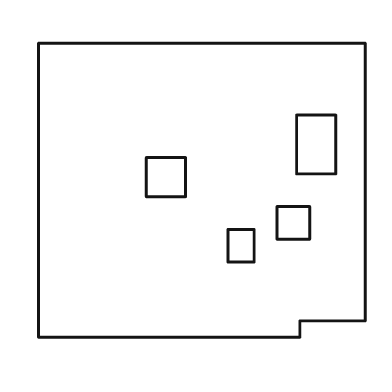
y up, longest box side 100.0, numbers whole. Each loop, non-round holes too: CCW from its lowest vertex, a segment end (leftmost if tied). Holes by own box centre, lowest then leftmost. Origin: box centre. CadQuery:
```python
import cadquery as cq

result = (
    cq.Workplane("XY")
    .moveTo(-50.0, -45.0)
    .lineTo(30.0, -45.0)
    .lineTo(30.0, -40.0)
    .lineTo(50.0, -40.0)
    .lineTo(50.0, 45.0)
    .lineTo(-50.0, 45.0)
    .close()
    .moveTo(8.0, -22.0)
    .lineTo(16.0, -22.0)
    .lineTo(16.0, -12.0)
    .lineTo(8.0, -12.0)
    .close()
    .moveTo(23.0, -15.0)
    .lineTo(33.0, -15.0)
    .lineTo(33.0, -5.0)
    .lineTo(23.0, -5.0)
    .close()
    .moveTo(-17.0, -2.0)
    .lineTo(-5.0, -2.0)
    .lineTo(-5.0, 10.0)
    .lineTo(-17.0, 10.0)
    .close()
    .moveTo(29.0, 5.0)
    .lineTo(41.0, 5.0)
    .lineTo(41.0, 23.0)
    .lineTo(29.0, 23.0)
    .close()
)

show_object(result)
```